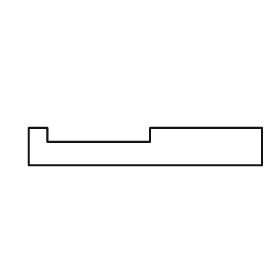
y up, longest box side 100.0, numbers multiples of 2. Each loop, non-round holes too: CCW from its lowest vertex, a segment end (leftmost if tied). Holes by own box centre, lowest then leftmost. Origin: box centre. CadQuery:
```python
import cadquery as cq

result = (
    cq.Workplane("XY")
    .moveTo(-50.0, -8.0)
    .lineTo(50.0, -8.0)
    .lineTo(50.0, 8.0)
    .lineTo(2.0, 8.0)
    .lineTo(2.0, 2.0)
    .lineTo(-42.0, 2.0)
    .lineTo(-42.0, 8.0)
    .lineTo(-50.0, 8.0)
    .close()
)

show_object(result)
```